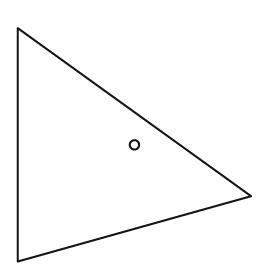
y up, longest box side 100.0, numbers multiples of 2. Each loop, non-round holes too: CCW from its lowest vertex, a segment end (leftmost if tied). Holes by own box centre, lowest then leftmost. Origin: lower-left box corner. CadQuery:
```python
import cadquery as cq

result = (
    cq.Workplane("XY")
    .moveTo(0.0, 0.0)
    .lineTo(100.0, 28.0)
    .lineTo(0.0, 100.0)
    .close()
    .moveTo(50.0, 50.0)
    .circle(2.0)
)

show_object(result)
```